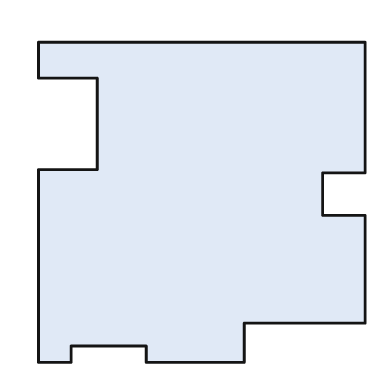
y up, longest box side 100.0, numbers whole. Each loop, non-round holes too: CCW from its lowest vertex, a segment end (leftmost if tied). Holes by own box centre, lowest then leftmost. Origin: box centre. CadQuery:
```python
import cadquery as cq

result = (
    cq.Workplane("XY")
    .moveTo(-50.0, -49.0)
    .lineTo(-40.0, -49.0)
    .lineTo(-40.0, -44.0)
    .lineTo(-17.0, -44.0)
    .lineTo(-17.0, -49.0)
    .lineTo(13.0, -49.0)
    .lineTo(13.0, -37.0)
    .lineTo(50.0, -37.0)
    .lineTo(50.0, -4.0)
    .lineTo(37.0, -4.0)
    .lineTo(37.0, 9.0)
    .lineTo(50.0, 9.0)
    .lineTo(50.0, 49.0)
    .lineTo(-50.0, 49.0)
    .lineTo(-50.0, 38.0)
    .lineTo(-32.0, 38.0)
    .lineTo(-32.0, 10.0)
    .lineTo(-50.0, 10.0)
    .close()
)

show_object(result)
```